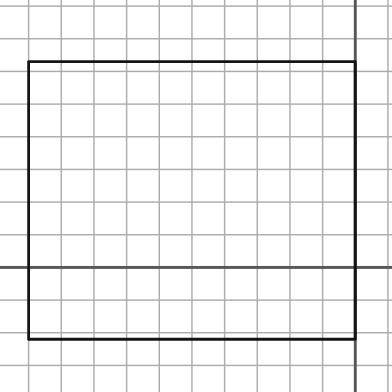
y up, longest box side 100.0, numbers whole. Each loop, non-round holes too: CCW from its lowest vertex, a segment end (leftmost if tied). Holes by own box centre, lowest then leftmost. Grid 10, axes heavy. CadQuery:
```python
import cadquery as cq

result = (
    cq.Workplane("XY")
    .moveTo(-100.0, -22.0)
    .lineTo(0.0, -22.0)
    .lineTo(0.0, 63.0)
    .lineTo(-100.0, 63.0)
    .close()
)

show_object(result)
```